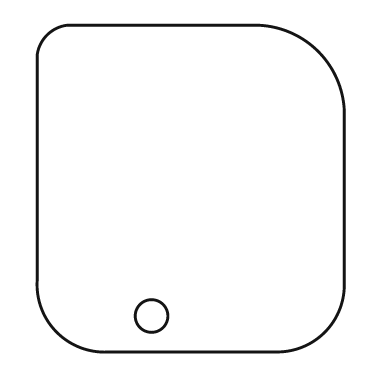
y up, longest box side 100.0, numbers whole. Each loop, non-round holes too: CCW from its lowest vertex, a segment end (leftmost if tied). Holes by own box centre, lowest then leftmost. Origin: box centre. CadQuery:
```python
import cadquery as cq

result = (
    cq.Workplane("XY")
    .moveTo(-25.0, -50.0)
    .lineTo(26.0, -50.0)
    .threePointArc((41.0, -44.0), (47.0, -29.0))
    .lineTo(47.0, 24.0)
    .threePointArc((39.0, 42.0), (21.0, 50.0))
    .lineTo(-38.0, 50.0)
    .threePointArc((-44.0, 47.0), (-47.0, 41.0))
    .lineTo(-47.0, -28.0)
    .threePointArc((-41.0, -44.0), (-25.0, -50.0))
    .close()
    .moveTo(-12.0, -39.0)
    .circle(5.0)
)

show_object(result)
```